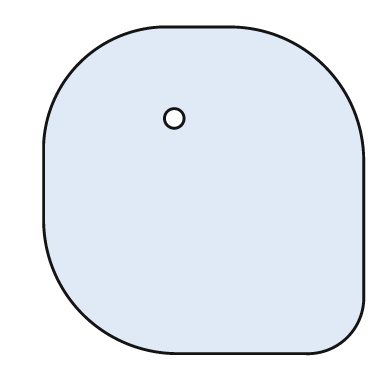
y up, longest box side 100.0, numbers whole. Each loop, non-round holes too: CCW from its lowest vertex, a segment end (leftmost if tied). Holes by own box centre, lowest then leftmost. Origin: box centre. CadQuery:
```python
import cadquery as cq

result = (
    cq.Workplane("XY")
    .moveTo(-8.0, -50.0)
    .lineTo(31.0, -50.0)
    .threePointArc((44.0, -45.0), (49.0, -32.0))
    .lineTo(49.0, 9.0)
    .threePointArc((37.0, 38.0), (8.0, 50.0))
    .lineTo(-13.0, 50.0)
    .threePointArc((-38.0, 39.0), (-49.0, 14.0))
    .lineTo(-49.0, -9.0)
    .threePointArc((-37.0, -38.0), (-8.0, -50.0))
    .close()
    .moveTo(-9.0, 22.0)
    .circle(3.0)
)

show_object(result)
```